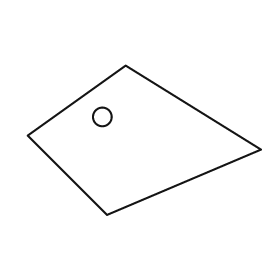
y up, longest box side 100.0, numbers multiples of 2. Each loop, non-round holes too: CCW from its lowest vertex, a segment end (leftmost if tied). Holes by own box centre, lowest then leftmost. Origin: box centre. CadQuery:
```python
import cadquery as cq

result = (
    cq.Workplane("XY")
    .moveTo(-16.0, -32.0)
    .lineTo(50.0, -4.0)
    .lineTo(-8.0, 32.0)
    .lineTo(-50.0, 2.0)
    .close()
    .moveTo(-18.0, 10.0)
    .circle(4.0)
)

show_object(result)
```